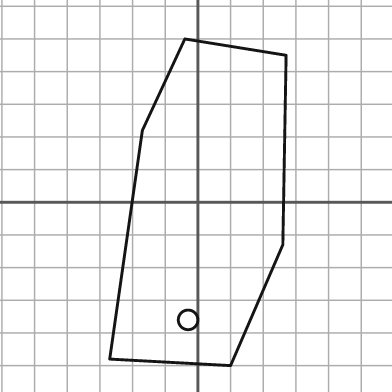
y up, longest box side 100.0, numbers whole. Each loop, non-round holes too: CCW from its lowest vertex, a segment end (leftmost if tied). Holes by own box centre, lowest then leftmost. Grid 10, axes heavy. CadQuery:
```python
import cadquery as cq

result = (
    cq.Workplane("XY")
    .moveTo(10.0, -50.0)
    .lineTo(26.0, -13.0)
    .lineTo(27.0, 45.0)
    .lineTo(-4.0, 50.0)
    .lineTo(-17.0, 22.0)
    .lineTo(-27.0, -48.0)
    .close()
    .moveTo(-3.0, -36.0)
    .circle(3.0)
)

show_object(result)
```